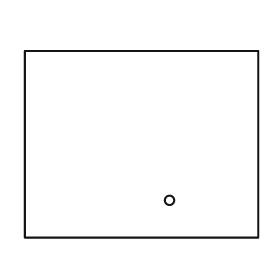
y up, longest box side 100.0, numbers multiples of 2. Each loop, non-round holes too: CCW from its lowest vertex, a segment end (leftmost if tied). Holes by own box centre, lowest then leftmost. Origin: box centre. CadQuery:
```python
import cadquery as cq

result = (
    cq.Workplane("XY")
    .moveTo(-50.0, -40.0)
    .lineTo(50.0, -40.0)
    .lineTo(50.0, 40.0)
    .lineTo(-50.0, 40.0)
    .close()
    .moveTo(12.0, -24.0)
    .circle(2.0)
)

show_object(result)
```